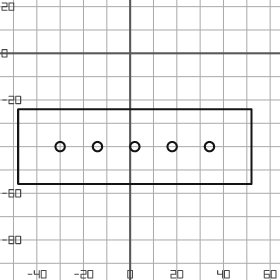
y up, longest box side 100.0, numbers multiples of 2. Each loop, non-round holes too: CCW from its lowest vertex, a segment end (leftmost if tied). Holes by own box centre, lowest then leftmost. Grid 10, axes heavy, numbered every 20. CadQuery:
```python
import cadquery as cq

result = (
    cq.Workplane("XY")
    .moveTo(-48.0, -56.0)
    .lineTo(52.0, -56.0)
    .lineTo(52.0, -24.0)
    .lineTo(-48.0, -24.0)
    .close()
    .moveTo(-30.0, -40.0)
    .circle(2.0)
    .moveTo(-14.0, -40.0)
    .circle(2.0)
    .moveTo(2.0, -40.0)
    .circle(2.0)
    .moveTo(18.0, -40.0)
    .circle(2.0)
    .moveTo(34.0, -40.0)
    .circle(2.0)
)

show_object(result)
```